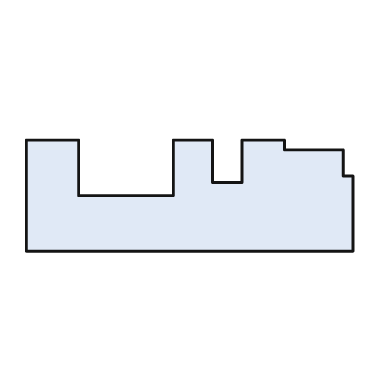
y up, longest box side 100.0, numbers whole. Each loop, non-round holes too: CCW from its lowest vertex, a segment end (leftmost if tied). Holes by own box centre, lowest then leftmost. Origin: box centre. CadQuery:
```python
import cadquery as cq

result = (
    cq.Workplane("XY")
    .moveTo(-50.0, -17.0)
    .lineTo(50.0, -17.0)
    .lineTo(50.0, 6.0)
    .lineTo(47.0, 6.0)
    .lineTo(47.0, 14.0)
    .lineTo(29.0, 14.0)
    .lineTo(29.0, 17.0)
    .lineTo(16.0, 17.0)
    .lineTo(16.0, 4.0)
    .lineTo(7.0, 4.0)
    .lineTo(7.0, 17.0)
    .lineTo(-5.0, 17.0)
    .lineTo(-5.0, 0.0)
    .lineTo(-34.0, 0.0)
    .lineTo(-34.0, 17.0)
    .lineTo(-50.0, 17.0)
    .close()
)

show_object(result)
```